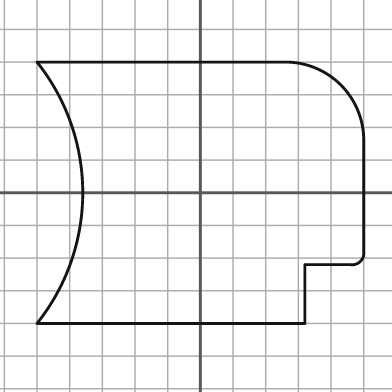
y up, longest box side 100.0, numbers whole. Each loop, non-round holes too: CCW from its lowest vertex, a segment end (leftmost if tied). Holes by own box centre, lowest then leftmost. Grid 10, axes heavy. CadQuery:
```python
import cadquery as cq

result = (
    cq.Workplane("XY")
    .moveTo(-50.0, -40.0)
    .lineTo(32.0, -40.0)
    .lineTo(32.0, -22.0)
    .lineTo(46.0, -22.0)
    .threePointArc((49.0, -21.0), (50.0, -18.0))
    .lineTo(50.0, 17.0)
    .threePointArc((43.0, 33.0), (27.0, 40.0))
    .lineTo(-50.0, 40.0)
    .threePointArc((-36.0, 0.0), (-50.0, -40.0))
    .close()
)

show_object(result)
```